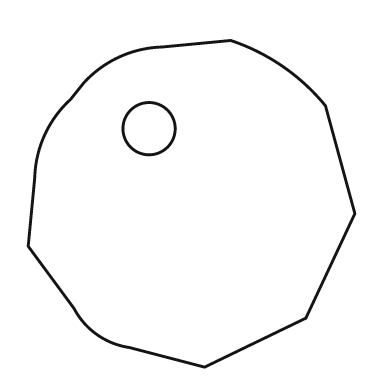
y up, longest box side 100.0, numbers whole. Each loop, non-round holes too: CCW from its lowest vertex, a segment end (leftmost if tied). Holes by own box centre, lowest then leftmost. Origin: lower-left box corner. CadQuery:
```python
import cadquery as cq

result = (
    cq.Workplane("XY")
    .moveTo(54.0, 0.0)
    .lineTo(85.0, 15.0)
    .lineTo(100.0, 47.0)
    .lineTo(91.0, 80.0)
    .threePointArc((78.0, 92.0), (62.0, 100.0))
    .lineTo(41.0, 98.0)
    .threePointArc((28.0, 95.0), (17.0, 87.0))
    .lineTo(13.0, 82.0)
    .threePointArc((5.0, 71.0), (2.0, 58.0))
    .lineTo(0.0, 37.0)
    .lineTo(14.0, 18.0)
    .threePointArc((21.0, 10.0), (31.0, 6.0))
    .close()
    .moveTo(37.0, 73.0)
    .circle(8.0)
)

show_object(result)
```